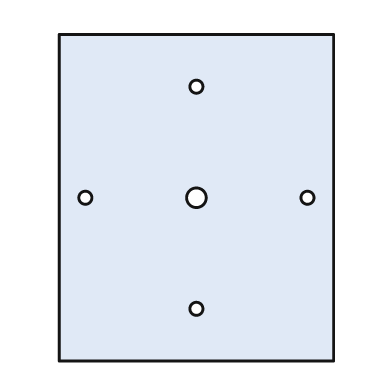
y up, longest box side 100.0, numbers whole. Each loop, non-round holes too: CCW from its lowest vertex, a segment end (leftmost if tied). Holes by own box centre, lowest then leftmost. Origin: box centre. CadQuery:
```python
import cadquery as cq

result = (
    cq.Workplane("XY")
    .moveTo(-42.0, -50.0)
    .lineTo(42.0, -50.0)
    .lineTo(42.0, 50.0)
    .lineTo(-42.0, 50.0)
    .close()
    .moveTo(0.0, -34.0)
    .circle(2.0)
    .moveTo(-34.0, 0.0)
    .circle(2.0)
    .moveTo(0.0, 0.0)
    .circle(3.0)
    .moveTo(34.0, 0.0)
    .circle(2.0)
    .moveTo(0.0, 34.0)
    .circle(2.0)
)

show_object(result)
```